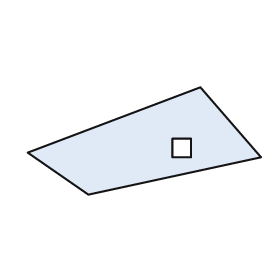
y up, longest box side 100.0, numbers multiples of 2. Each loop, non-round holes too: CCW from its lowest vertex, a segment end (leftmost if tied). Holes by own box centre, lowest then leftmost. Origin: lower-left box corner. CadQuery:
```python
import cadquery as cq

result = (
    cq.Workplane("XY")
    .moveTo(26.0, 0.0)
    .lineTo(100.0, 16.0)
    .lineTo(74.0, 46.0)
    .lineTo(0.0, 18.0)
    .close()
    .moveTo(62.0, 16.0)
    .lineTo(70.0, 16.0)
    .lineTo(70.0, 24.0)
    .lineTo(62.0, 24.0)
    .close()
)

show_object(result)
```